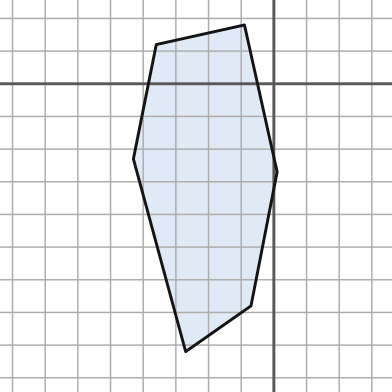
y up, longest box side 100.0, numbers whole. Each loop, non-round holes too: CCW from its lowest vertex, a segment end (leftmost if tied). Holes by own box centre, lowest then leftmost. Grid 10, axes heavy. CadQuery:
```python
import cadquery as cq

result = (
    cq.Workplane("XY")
    .moveTo(-27.0, -82.0)
    .lineTo(-7.0, -68.0)
    .lineTo(1.0, -27.0)
    .lineTo(-9.0, 18.0)
    .lineTo(-36.0, 12.0)
    .lineTo(-43.0, -23.0)
    .close()
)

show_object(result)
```